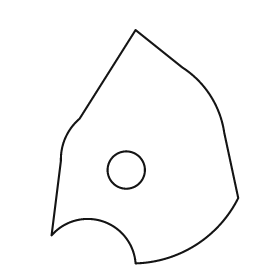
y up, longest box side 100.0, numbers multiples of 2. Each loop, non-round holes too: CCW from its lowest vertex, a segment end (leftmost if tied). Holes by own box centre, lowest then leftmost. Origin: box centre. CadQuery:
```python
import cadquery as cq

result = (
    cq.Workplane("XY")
    .moveTo(-4.0, -50.0)
    .threePointArc((22.0, -42.0), (40.0, -22.0))
    .lineTo(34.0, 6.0)
    .threePointArc((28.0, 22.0), (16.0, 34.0))
    .lineTo(-4.0, 50.0)
    .lineTo(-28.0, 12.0)
    .threePointArc((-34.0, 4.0), (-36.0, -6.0))
    .lineTo(-40.0, -38.0)
    .threePointArc((-18.0, -32.0), (-4.0, -50.0))
    .close()
    .moveTo(-8.0, -10.0)
    .circle(8.0)
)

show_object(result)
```